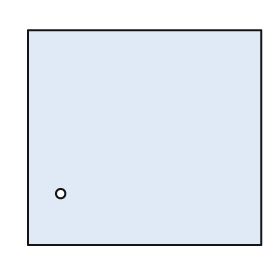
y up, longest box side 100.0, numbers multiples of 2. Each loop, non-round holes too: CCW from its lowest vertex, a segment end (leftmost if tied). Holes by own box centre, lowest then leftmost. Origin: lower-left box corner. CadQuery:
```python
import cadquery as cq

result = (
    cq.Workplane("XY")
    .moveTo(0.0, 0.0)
    .lineTo(100.0, 0.0)
    .lineTo(100.0, 92.0)
    .lineTo(0.0, 92.0)
    .close()
    .moveTo(14.0, 22.0)
    .circle(2.0)
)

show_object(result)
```